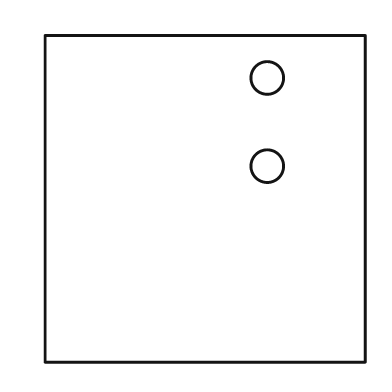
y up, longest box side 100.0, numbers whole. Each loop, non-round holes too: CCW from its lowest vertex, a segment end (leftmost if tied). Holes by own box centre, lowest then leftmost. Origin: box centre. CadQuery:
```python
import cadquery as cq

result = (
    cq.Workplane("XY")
    .moveTo(-49.0, -50.0)
    .lineTo(49.0, -50.0)
    .lineTo(49.0, 50.0)
    .lineTo(-49.0, 50.0)
    .close()
    .moveTo(19.0, 10.0)
    .circle(5.0)
    .moveTo(19.0, 37.0)
    .circle(5.0)
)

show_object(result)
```